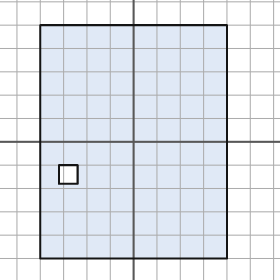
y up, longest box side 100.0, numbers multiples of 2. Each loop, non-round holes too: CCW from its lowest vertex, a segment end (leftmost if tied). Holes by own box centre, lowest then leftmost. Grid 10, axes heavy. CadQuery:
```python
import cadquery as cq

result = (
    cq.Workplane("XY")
    .moveTo(-40.0, -50.0)
    .lineTo(40.0, -50.0)
    .lineTo(40.0, 50.0)
    .lineTo(-40.0, 50.0)
    .close()
    .moveTo(-32.0, -18.0)
    .lineTo(-24.0, -18.0)
    .lineTo(-24.0, -10.0)
    .lineTo(-32.0, -10.0)
    .close()
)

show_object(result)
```